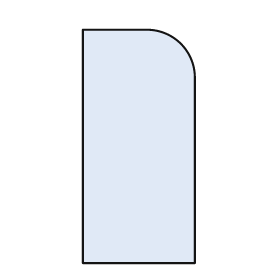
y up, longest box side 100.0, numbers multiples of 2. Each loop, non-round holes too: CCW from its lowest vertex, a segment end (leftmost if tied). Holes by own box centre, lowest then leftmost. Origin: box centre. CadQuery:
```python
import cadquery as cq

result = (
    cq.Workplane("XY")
    .moveTo(-24.0, -50.0)
    .lineTo(24.0, -50.0)
    .lineTo(24.0, 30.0)
    .threePointArc((18.0, 44.0), (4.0, 50.0))
    .lineTo(-24.0, 50.0)
    .close()
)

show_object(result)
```